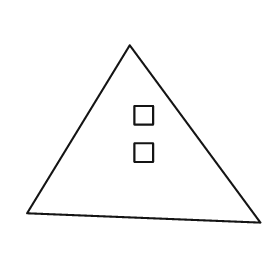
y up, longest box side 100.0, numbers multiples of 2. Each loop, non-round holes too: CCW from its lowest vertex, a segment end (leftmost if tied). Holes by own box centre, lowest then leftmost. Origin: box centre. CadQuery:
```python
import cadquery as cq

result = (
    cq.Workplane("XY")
    .moveTo(50.0, -38.0)
    .lineTo(-6.0, 38.0)
    .lineTo(-50.0, -34.0)
    .close()
    .moveTo(-4.0, -12.0)
    .lineTo(4.0, -12.0)
    .lineTo(4.0, -4.0)
    .lineTo(-4.0, -4.0)
    .close()
    .moveTo(-4.0, 4.0)
    .lineTo(4.0, 4.0)
    .lineTo(4.0, 12.0)
    .lineTo(-4.0, 12.0)
    .close()
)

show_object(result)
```